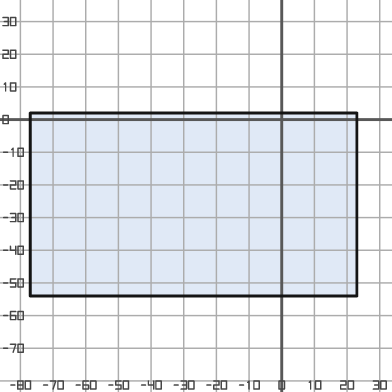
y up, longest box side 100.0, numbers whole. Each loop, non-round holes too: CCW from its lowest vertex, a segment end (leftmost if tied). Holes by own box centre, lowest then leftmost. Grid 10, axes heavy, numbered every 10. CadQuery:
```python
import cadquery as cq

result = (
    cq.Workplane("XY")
    .moveTo(-77.0, -54.0)
    .lineTo(23.0, -54.0)
    .lineTo(23.0, 2.0)
    .lineTo(-77.0, 2.0)
    .close()
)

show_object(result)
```